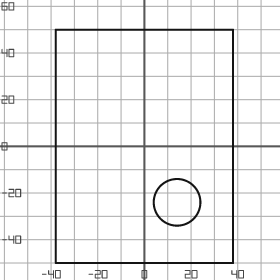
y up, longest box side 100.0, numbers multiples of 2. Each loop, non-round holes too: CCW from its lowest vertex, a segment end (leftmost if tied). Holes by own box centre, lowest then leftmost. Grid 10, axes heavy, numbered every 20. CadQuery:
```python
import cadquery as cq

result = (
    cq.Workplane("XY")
    .moveTo(-38.0, -50.0)
    .lineTo(38.0, -50.0)
    .lineTo(38.0, 50.0)
    .lineTo(-38.0, 50.0)
    .close()
    .moveTo(14.0, -24.0)
    .circle(10.0)
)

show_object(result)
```